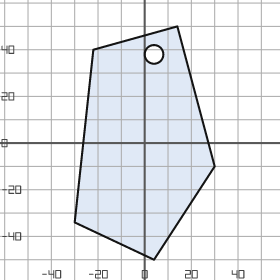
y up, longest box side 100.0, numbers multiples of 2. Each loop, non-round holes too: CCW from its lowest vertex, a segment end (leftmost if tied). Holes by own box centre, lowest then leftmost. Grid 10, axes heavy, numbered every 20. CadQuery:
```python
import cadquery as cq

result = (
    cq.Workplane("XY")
    .moveTo(4.0, -50.0)
    .lineTo(30.0, -10.0)
    .lineTo(14.0, 50.0)
    .lineTo(-22.0, 40.0)
    .lineTo(-30.0, -34.0)
    .close()
    .moveTo(4.0, 38.0)
    .circle(4.0)
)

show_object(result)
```